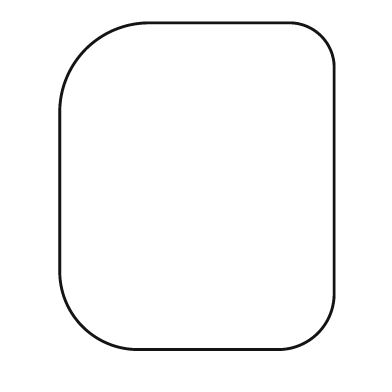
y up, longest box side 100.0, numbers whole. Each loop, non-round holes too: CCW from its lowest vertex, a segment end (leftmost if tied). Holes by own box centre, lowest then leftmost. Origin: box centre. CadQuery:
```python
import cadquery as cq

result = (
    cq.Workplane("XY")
    .moveTo(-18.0, -50.0)
    .lineTo(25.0, -50.0)
    .threePointArc((37.0, -45.0), (42.0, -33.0))
    .lineTo(42.0, 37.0)
    .threePointArc((38.0, 46.0), (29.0, 50.0))
    .lineTo(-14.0, 50.0)
    .threePointArc((-34.0, 42.0), (-42.0, 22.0))
    .lineTo(-42.0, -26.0)
    .threePointArc((-35.0, -43.0), (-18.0, -50.0))
    .close()
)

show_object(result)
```